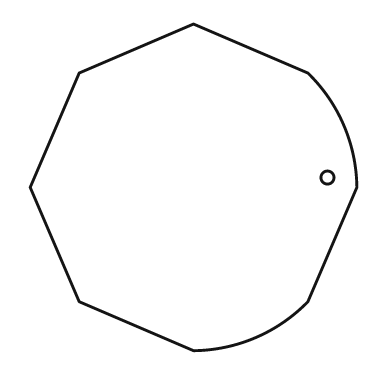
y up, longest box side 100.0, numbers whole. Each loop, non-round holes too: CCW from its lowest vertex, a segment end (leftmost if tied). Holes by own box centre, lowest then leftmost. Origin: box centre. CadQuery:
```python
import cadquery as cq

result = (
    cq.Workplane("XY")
    .moveTo(0.0, -50.0)
    .threePointArc((19.0, -46.0), (35.0, -35.0))
    .lineTo(50.0, 0.0)
    .threePointArc((46.0, 19.0), (35.0, 35.0))
    .lineTo(0.0, 50.0)
    .lineTo(-35.0, 35.0)
    .lineTo(-50.0, 0.0)
    .lineTo(-35.0, -35.0)
    .close()
    .moveTo(41.0, 3.0)
    .circle(2.0)
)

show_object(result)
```